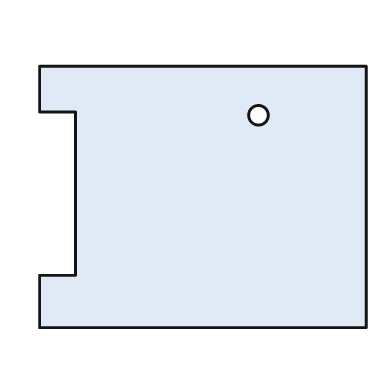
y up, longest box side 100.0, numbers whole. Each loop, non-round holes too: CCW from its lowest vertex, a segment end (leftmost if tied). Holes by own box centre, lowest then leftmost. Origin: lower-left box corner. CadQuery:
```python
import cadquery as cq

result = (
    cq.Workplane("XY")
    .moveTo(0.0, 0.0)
    .lineTo(100.0, 0.0)
    .lineTo(100.0, 80.0)
    .lineTo(0.0, 80.0)
    .lineTo(0.0, 66.0)
    .lineTo(11.0, 66.0)
    .lineTo(11.0, 16.0)
    .lineTo(0.0, 16.0)
    .close()
    .moveTo(67.0, 65.0)
    .circle(3.0)
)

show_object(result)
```